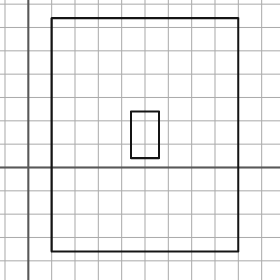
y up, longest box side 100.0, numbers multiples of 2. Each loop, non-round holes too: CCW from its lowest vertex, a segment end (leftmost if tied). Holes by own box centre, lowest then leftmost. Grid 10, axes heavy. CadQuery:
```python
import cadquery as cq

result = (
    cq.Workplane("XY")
    .moveTo(10.0, -36.0)
    .lineTo(90.0, -36.0)
    .lineTo(90.0, 64.0)
    .lineTo(10.0, 64.0)
    .close()
    .moveTo(44.0, 4.0)
    .lineTo(56.0, 4.0)
    .lineTo(56.0, 24.0)
    .lineTo(44.0, 24.0)
    .close()
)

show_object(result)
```